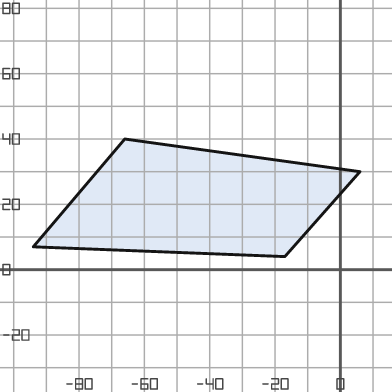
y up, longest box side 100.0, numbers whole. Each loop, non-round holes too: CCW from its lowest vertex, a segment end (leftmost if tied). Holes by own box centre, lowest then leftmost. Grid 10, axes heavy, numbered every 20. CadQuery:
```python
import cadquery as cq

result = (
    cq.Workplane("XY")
    .moveTo(-17.0, 4.0)
    .lineTo(6.0, 30.0)
    .lineTo(-66.0, 40.0)
    .lineTo(-94.0, 7.0)
    .close()
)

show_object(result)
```